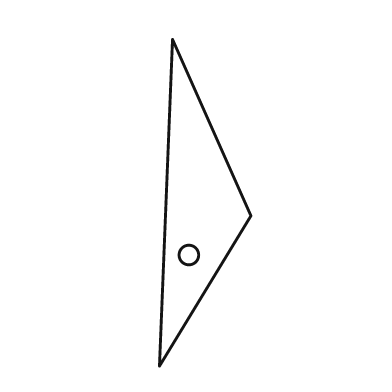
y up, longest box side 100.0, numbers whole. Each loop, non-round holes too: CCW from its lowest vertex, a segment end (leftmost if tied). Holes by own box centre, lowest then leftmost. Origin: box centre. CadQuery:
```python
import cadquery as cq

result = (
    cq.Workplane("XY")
    .moveTo(-14.0, -50.0)
    .lineTo(14.0, -4.0)
    .lineTo(-10.0, 50.0)
    .close()
    .moveTo(-5.0, -16.0)
    .circle(3.0)
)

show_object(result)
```